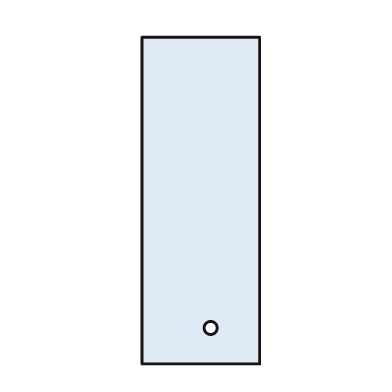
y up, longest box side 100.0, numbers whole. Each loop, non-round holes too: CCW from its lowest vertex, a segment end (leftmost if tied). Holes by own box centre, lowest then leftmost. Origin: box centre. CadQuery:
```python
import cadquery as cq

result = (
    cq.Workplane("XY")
    .moveTo(-18.0, -50.0)
    .lineTo(18.0, -50.0)
    .lineTo(18.0, 50.0)
    .lineTo(-18.0, 50.0)
    .close()
    .moveTo(3.0, -39.0)
    .circle(2.0)
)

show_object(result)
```